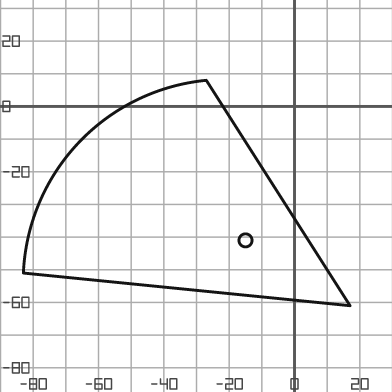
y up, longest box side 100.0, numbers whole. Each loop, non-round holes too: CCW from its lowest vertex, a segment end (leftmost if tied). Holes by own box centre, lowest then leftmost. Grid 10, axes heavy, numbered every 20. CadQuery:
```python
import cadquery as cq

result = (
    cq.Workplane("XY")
    .moveTo(17.0, -61.0)
    .lineTo(-27.0, 8.0)
    .threePointArc((-66.0, -11.0), (-83.0, -51.0))
    .close()
    .moveTo(-15.0, -41.0)
    .circle(2.0)
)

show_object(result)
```